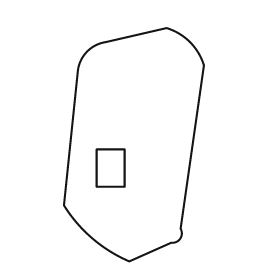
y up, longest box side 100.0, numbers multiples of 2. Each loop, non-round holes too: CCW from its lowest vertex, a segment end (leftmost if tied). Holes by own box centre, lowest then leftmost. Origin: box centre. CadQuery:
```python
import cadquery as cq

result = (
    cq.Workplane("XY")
    .moveTo(-2.0, -50.0)
    .lineTo(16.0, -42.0)
    .threePointArc((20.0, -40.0), (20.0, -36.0))
    .lineTo(30.0, 34.0)
    .threePointArc((24.0, 44.0), (14.0, 50.0))
    .lineTo(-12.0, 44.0)
    .threePointArc((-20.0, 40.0), (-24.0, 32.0))
    .lineTo(-30.0, -26.0)
    .threePointArc((-18.0, -40.0), (-2.0, -50.0))
    .close()
    .moveTo(-16.0, -18.0)
    .lineTo(-4.0, -18.0)
    .lineTo(-4.0, -2.0)
    .lineTo(-16.0, -2.0)
    .close()
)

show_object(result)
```